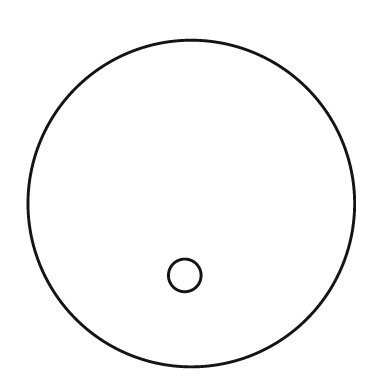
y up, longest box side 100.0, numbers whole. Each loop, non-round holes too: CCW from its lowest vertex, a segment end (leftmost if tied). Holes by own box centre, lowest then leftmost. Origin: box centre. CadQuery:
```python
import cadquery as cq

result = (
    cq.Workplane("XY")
    .moveTo(0.0, 0.0)
    .circle(50.0)
    .moveTo(-2.0, -22.0)
    .circle(5.0)
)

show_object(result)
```